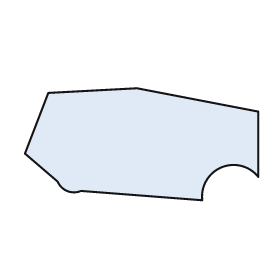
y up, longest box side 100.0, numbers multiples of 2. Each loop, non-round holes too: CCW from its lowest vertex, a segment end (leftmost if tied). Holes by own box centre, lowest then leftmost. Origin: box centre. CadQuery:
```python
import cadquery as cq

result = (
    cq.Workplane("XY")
    .moveTo(26.0, -24.0)
    .threePointArc((34.0, -10.0), (50.0, -14.0))
    .lineTo(50.0, 14.0)
    .lineTo(-2.0, 24.0)
    .lineTo(-40.0, 22.0)
    .lineTo(-50.0, -4.0)
    .lineTo(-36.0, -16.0)
    .threePointArc((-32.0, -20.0), (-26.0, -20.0))
    .close()
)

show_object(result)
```